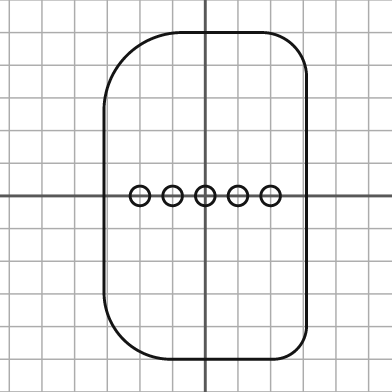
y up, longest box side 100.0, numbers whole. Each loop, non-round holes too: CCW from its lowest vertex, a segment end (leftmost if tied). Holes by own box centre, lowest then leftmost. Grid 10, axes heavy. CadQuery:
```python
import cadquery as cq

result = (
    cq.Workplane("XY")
    .moveTo(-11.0, -50.0)
    .lineTo(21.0, -50.0)
    .threePointArc((28.0, -47.0), (31.0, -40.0))
    .lineTo(31.0, 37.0)
    .threePointArc((27.0, 46.0), (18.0, 50.0))
    .lineTo(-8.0, 50.0)
    .threePointArc((-24.0, 43.0), (-31.0, 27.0))
    .lineTo(-31.0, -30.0)
    .threePointArc((-25.0, -44.0), (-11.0, -50.0))
    .close()
    .moveTo(-20.0, 0.0)
    .circle(3.0)
    .moveTo(-10.0, 0.0)
    .circle(3.0)
    .moveTo(0.0, 0.0)
    .circle(3.0)
    .moveTo(10.0, 0.0)
    .circle(3.0)
    .moveTo(20.0, 0.0)
    .circle(3.0)
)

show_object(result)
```